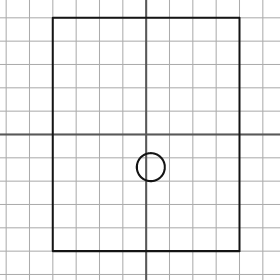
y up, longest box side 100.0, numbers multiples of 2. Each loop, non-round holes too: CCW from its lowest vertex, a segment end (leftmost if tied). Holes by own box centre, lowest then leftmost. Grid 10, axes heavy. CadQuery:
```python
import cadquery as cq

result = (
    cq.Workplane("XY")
    .moveTo(-40.0, -50.0)
    .lineTo(40.0, -50.0)
    .lineTo(40.0, 50.0)
    .lineTo(-40.0, 50.0)
    .close()
    .moveTo(2.0, -14.0)
    .circle(6.0)
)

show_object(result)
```